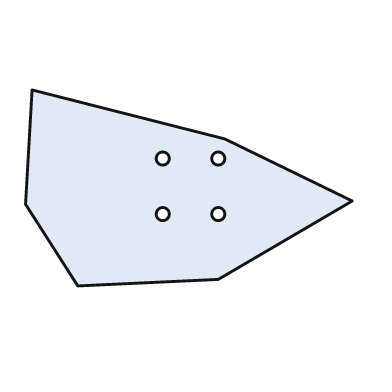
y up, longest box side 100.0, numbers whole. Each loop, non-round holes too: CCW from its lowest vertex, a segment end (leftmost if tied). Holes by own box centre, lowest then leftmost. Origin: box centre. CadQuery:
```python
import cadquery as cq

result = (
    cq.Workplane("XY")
    .moveTo(-34.0, -30.0)
    .lineTo(9.0, -28.0)
    .lineTo(50.0, -4.0)
    .lineTo(11.0, 15.0)
    .lineTo(-48.0, 30.0)
    .lineTo(-50.0, -5.0)
    .close()
    .moveTo(-8.0, -8.0)
    .circle(2.0)
    .moveTo(9.0, -8.0)
    .circle(2.0)
    .moveTo(-8.0, 9.0)
    .circle(2.0)
    .moveTo(9.0, 9.0)
    .circle(2.0)
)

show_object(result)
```